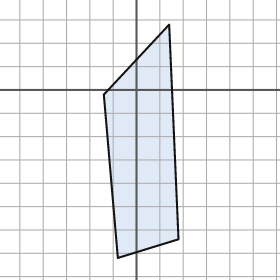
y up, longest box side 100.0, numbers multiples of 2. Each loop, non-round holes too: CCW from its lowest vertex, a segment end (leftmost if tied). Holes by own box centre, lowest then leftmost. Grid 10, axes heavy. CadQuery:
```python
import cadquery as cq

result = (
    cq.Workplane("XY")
    .moveTo(-8.0, -72.0)
    .lineTo(18.0, -64.0)
    .lineTo(14.0, 28.0)
    .lineTo(-14.0, -2.0)
    .close()
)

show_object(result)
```